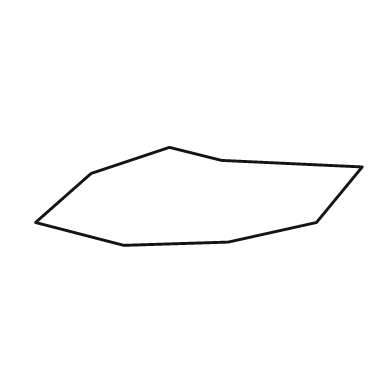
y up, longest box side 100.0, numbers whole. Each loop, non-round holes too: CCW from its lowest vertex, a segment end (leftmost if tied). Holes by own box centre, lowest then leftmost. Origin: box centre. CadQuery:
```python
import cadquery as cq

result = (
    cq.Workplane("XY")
    .moveTo(-23.0, -15.0)
    .lineTo(9.0, -14.0)
    .lineTo(36.0, -8.0)
    .lineTo(50.0, 9.0)
    .lineTo(7.0, 11.0)
    .lineTo(-9.0, 15.0)
    .lineTo(-33.0, 7.0)
    .lineTo(-50.0, -8.0)
    .close()
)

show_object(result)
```